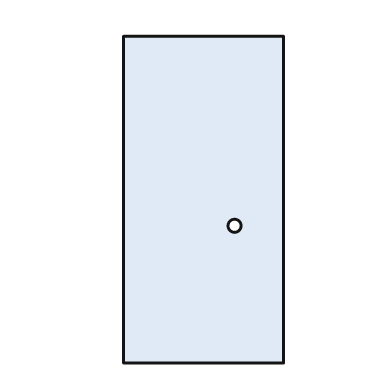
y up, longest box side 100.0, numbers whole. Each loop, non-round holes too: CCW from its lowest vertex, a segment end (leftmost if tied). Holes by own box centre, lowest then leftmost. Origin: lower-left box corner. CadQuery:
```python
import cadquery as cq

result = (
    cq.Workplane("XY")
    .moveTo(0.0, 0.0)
    .lineTo(49.0, 0.0)
    .lineTo(49.0, 100.0)
    .lineTo(0.0, 100.0)
    .close()
    .moveTo(34.0, 42.0)
    .circle(2.0)
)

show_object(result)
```